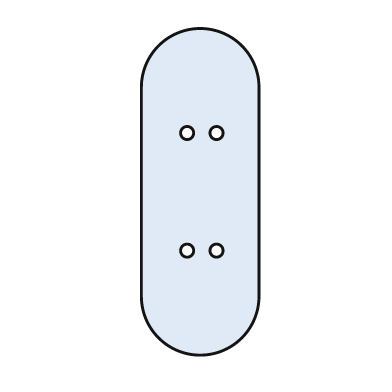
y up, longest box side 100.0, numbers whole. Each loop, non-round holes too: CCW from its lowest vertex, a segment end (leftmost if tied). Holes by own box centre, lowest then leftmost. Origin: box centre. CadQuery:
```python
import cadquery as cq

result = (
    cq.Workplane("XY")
    .moveTo(-18.0, -32.0)
    .threePointArc((0.0, -50.0), (18.0, -32.0))
    .lineTo(18.0, 32.0)
    .threePointArc((0.0, 50.0), (-18.0, 32.0))
    .close()
    .moveTo(-4.0, -18.0)
    .circle(2.0)
    .moveTo(5.0, -18.0)
    .circle(2.0)
    .moveTo(-4.0, 18.0)
    .circle(2.0)
    .moveTo(5.0, 18.0)
    .circle(2.0)
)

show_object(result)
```